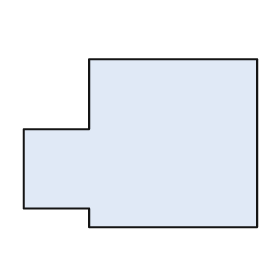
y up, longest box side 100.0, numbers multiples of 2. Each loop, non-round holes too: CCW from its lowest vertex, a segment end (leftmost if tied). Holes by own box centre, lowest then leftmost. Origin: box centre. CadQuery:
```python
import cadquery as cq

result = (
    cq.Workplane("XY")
    .moveTo(-22.0, -36.0)
    .lineTo(50.0, -36.0)
    .lineTo(50.0, 36.0)
    .lineTo(-22.0, 36.0)
    .lineTo(-22.0, 6.0)
    .lineTo(-50.0, 6.0)
    .lineTo(-50.0, -28.0)
    .lineTo(-22.0, -28.0)
    .close()
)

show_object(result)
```